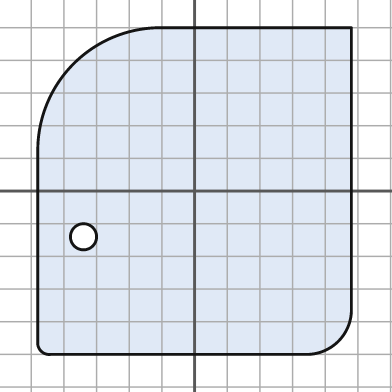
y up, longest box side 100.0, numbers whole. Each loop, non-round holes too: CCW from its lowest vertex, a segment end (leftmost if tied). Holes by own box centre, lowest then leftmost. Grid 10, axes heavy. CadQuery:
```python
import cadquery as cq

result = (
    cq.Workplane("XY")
    .moveTo(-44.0, -50.0)
    .lineTo(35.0, -50.0)
    .threePointArc((44.0, -46.0), (48.0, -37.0))
    .lineTo(48.0, 50.0)
    .lineTo(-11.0, 50.0)
    .threePointArc((-37.0, 39.0), (-48.0, 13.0))
    .lineTo(-48.0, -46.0)
    .threePointArc((-47.0, -49.0), (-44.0, -50.0))
    .close()
    .moveTo(-34.0, -14.0)
    .circle(4.0)
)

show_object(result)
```